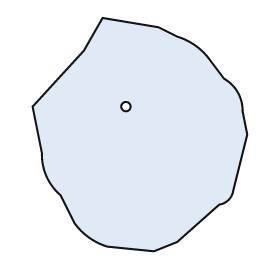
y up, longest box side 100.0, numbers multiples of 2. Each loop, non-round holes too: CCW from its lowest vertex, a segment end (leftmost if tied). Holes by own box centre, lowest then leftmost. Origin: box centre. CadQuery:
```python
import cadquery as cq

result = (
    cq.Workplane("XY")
    .moveTo(6.0, -50.0)
    .lineTo(16.0, -46.0)
    .lineTo(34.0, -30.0)
    .threePointArc((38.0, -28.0), (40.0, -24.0))
    .lineTo(46.0, 0.0)
    .lineTo(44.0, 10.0)
    .threePointArc((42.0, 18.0), (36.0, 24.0))
    .lineTo(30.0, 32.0)
    .threePointArc((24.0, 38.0), (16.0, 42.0))
    .lineTo(8.0, 46.0)
    .lineTo(-16.0, 50.0)
    .lineTo(-24.0, 36.0)
    .lineTo(-46.0, 12.0)
    .lineTo(-42.0, -8.0)
    .threePointArc((-40.0, -18.0), (-34.0, -26.0))
    .lineTo(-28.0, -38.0)
    .threePointArc((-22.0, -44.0), (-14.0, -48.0))
    .close()
    .moveTo(-6.0, 12.0)
    .circle(2.0)
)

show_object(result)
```